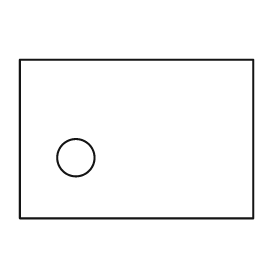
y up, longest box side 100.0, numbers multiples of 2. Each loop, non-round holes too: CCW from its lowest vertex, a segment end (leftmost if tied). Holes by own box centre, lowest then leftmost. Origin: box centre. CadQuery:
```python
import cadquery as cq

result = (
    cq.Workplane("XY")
    .moveTo(-50.0, -34.0)
    .lineTo(50.0, -34.0)
    .lineTo(50.0, 34.0)
    .lineTo(-50.0, 34.0)
    .close()
    .moveTo(-26.0, -8.0)
    .circle(8.0)
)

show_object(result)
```